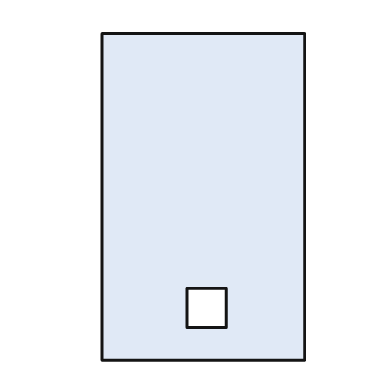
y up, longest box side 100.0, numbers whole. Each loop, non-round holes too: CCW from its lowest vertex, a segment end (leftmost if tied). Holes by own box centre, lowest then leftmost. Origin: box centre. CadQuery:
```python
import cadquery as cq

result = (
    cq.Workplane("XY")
    .moveTo(-31.0, -50.0)
    .lineTo(31.0, -50.0)
    .lineTo(31.0, 50.0)
    .lineTo(-31.0, 50.0)
    .close()
    .moveTo(-5.0, -40.0)
    .lineTo(7.0, -40.0)
    .lineTo(7.0, -28.0)
    .lineTo(-5.0, -28.0)
    .close()
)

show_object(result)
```